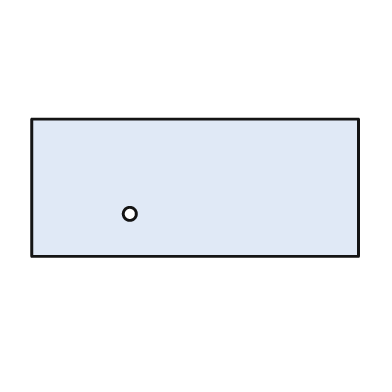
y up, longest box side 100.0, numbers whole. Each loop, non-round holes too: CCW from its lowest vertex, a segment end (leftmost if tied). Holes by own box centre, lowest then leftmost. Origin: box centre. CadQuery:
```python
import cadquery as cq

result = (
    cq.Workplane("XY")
    .moveTo(-50.0, -21.0)
    .lineTo(50.0, -21.0)
    .lineTo(50.0, 21.0)
    .lineTo(-50.0, 21.0)
    .close()
    .moveTo(-20.0, -8.0)
    .circle(2.0)
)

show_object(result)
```